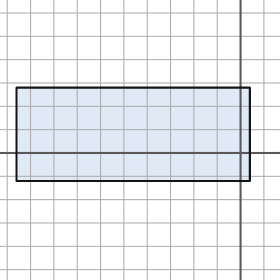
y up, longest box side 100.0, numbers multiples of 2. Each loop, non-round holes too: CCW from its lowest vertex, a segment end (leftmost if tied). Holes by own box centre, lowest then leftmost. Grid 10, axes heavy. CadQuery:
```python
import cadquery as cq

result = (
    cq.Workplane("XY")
    .moveTo(-96.0, -12.0)
    .lineTo(4.0, -12.0)
    .lineTo(4.0, 28.0)
    .lineTo(-96.0, 28.0)
    .close()
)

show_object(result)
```